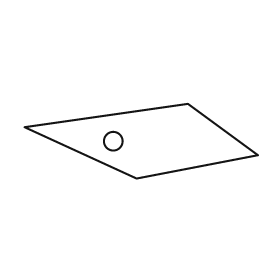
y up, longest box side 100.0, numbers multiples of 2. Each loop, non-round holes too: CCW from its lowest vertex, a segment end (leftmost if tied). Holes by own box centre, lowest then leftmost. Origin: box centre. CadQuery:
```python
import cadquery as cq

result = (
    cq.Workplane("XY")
    .moveTo(-2.0, -16.0)
    .lineTo(50.0, -6.0)
    .lineTo(20.0, 16.0)
    .lineTo(-50.0, 6.0)
    .close()
    .moveTo(-12.0, 0.0)
    .circle(4.0)
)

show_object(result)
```